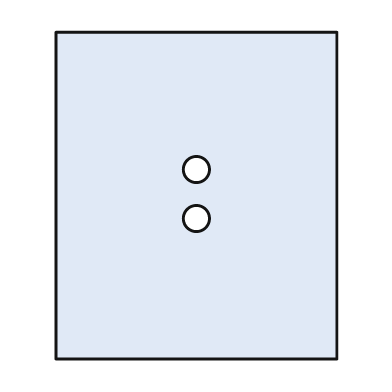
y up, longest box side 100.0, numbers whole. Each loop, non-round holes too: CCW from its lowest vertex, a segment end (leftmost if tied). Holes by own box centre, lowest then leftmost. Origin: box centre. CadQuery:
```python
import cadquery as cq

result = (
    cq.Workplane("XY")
    .moveTo(-43.0, -50.0)
    .lineTo(43.0, -50.0)
    .lineTo(43.0, 50.0)
    .lineTo(-43.0, 50.0)
    .close()
    .moveTo(0.0, -7.0)
    .circle(4.0)
    .moveTo(0.0, 8.0)
    .circle(4.0)
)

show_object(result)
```